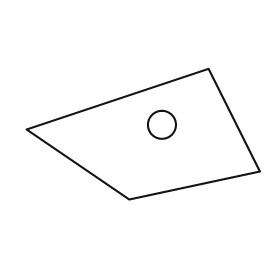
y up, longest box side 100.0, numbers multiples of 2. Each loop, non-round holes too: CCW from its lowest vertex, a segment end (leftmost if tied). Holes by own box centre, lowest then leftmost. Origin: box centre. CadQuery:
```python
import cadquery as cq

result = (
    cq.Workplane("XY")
    .moveTo(-6.0, -28.0)
    .lineTo(50.0, -16.0)
    .lineTo(28.0, 28.0)
    .lineTo(-50.0, 2.0)
    .close()
    .moveTo(8.0, 4.0)
    .circle(6.0)
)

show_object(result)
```